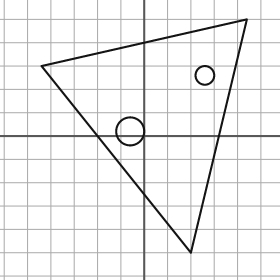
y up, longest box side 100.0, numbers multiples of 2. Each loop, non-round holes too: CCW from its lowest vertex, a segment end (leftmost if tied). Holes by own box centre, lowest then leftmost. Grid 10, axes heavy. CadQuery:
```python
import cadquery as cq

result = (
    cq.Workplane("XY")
    .moveTo(20.0, -50.0)
    .lineTo(44.0, 50.0)
    .lineTo(-44.0, 30.0)
    .close()
    .moveTo(-6.0, 2.0)
    .circle(6.0)
    .moveTo(26.0, 26.0)
    .circle(4.0)
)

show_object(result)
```